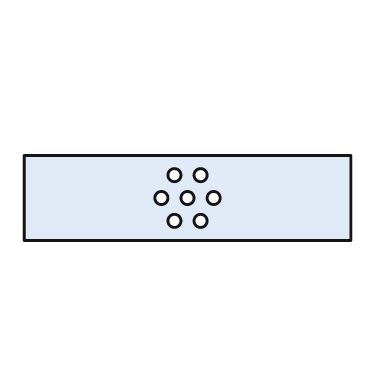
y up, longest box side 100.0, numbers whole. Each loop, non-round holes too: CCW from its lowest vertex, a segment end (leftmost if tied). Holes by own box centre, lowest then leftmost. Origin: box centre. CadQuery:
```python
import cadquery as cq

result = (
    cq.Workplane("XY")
    .moveTo(-50.0, -13.0)
    .lineTo(50.0, -13.0)
    .lineTo(50.0, 13.0)
    .lineTo(-50.0, 13.0)
    .close()
    .moveTo(-4.0, -7.0)
    .circle(2.0)
    .moveTo(4.0, -7.0)
    .circle(2.0)
    .moveTo(-8.0, 0.0)
    .circle(2.0)
    .moveTo(0.0, 0.0)
    .circle(2.0)
    .moveTo(8.0, 0.0)
    .circle(2.0)
    .moveTo(-4.0, 7.0)
    .circle(2.0)
    .moveTo(4.0, 7.0)
    .circle(2.0)
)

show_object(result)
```